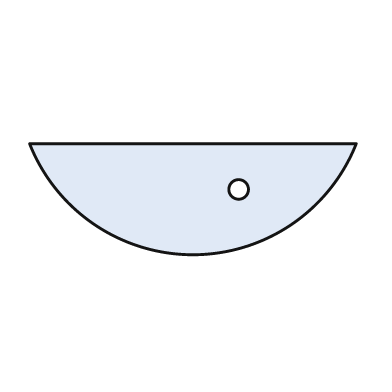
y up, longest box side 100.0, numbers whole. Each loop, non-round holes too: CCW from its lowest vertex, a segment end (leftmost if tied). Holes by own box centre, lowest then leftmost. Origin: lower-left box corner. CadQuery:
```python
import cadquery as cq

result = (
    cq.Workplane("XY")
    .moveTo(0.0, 34.0)
    .threePointArc((50.0, 0.0), (100.0, 34.0))
    .close()
    .moveTo(64.0, 20.0)
    .circle(3.0)
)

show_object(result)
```